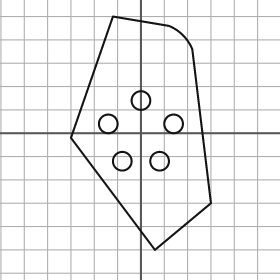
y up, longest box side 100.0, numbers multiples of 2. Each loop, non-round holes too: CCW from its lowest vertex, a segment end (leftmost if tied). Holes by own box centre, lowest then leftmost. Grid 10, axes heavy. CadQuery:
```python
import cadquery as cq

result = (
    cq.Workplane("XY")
    .moveTo(6.0, -50.0)
    .lineTo(30.0, -30.0)
    .lineTo(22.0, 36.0)
    .threePointArc((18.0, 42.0), (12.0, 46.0))
    .lineTo(-12.0, 50.0)
    .lineTo(-30.0, -2.0)
    .close()
    .moveTo(-8.0, -12.0)
    .circle(4.0)
    .moveTo(8.0, -12.0)
    .circle(4.0)
    .moveTo(-14.0, 4.0)
    .circle(4.0)
    .moveTo(14.0, 4.0)
    .circle(4.0)
    .moveTo(0.0, 14.0)
    .circle(4.0)
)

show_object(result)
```